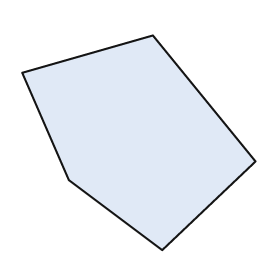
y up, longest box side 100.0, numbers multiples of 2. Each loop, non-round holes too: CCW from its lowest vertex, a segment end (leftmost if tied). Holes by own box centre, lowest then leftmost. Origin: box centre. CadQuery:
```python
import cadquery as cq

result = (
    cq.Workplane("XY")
    .moveTo(10.0, -46.0)
    .lineTo(50.0, -8.0)
    .lineTo(6.0, 46.0)
    .lineTo(-50.0, 30.0)
    .lineTo(-30.0, -16.0)
    .close()
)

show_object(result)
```